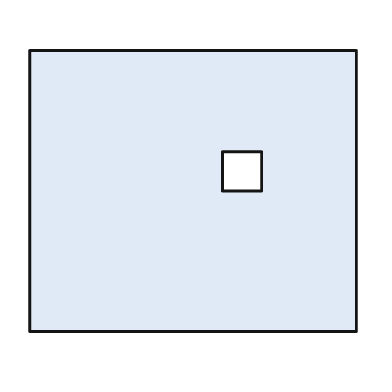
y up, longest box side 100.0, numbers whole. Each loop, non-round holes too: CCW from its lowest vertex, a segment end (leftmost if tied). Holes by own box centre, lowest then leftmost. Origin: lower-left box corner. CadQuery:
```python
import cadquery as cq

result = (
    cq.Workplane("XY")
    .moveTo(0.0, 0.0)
    .lineTo(100.0, 0.0)
    .lineTo(100.0, 86.0)
    .lineTo(0.0, 86.0)
    .close()
    .moveTo(59.0, 43.0)
    .lineTo(71.0, 43.0)
    .lineTo(71.0, 55.0)
    .lineTo(59.0, 55.0)
    .close()
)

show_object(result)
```